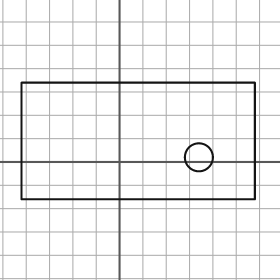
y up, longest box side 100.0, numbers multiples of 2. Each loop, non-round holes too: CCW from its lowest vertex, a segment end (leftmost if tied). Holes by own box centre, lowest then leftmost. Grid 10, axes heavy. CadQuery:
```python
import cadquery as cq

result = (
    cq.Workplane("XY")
    .moveTo(-42.0, -16.0)
    .lineTo(58.0, -16.0)
    .lineTo(58.0, 34.0)
    .lineTo(-42.0, 34.0)
    .close()
    .moveTo(34.0, 2.0)
    .circle(6.0)
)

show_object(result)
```